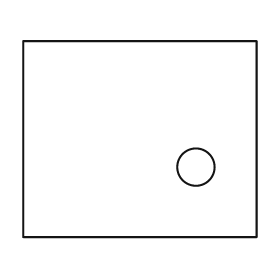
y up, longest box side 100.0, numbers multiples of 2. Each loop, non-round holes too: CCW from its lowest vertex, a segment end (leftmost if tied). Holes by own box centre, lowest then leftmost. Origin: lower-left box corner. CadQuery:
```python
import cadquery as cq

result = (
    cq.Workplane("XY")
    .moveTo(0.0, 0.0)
    .lineTo(100.0, 0.0)
    .lineTo(100.0, 84.0)
    .lineTo(0.0, 84.0)
    .close()
    .moveTo(74.0, 30.0)
    .circle(8.0)
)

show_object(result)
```